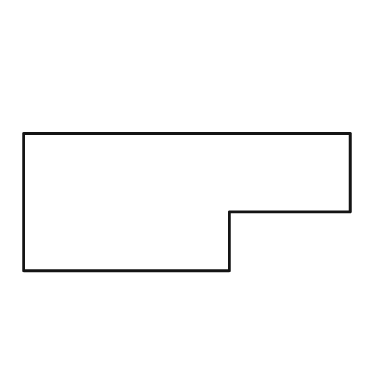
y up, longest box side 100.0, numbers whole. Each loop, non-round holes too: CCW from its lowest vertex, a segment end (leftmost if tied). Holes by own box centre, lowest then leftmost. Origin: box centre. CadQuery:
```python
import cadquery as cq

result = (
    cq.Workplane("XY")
    .moveTo(-50.0, -21.0)
    .lineTo(13.0, -21.0)
    .lineTo(13.0, -3.0)
    .lineTo(50.0, -3.0)
    .lineTo(50.0, 21.0)
    .lineTo(-50.0, 21.0)
    .close()
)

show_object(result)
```